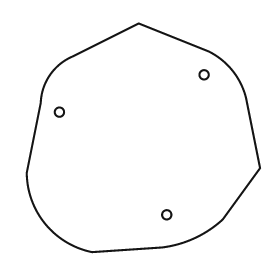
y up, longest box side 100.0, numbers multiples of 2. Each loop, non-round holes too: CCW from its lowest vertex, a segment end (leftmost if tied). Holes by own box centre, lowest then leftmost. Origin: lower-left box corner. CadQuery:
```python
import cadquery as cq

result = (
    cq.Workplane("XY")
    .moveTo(28.0, 0.0)
    .lineTo(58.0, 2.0)
    .threePointArc((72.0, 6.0), (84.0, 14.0))
    .lineTo(100.0, 36.0)
    .lineTo(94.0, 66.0)
    .threePointArc((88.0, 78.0), (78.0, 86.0))
    .lineTo(48.0, 98.0)
    .lineTo(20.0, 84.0)
    .threePointArc((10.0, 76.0), (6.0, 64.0))
    .lineTo(0.0, 34.0)
    .threePointArc((8.0, 12.0), (28.0, 0.0))
    .close()
    .moveTo(60.0, 16.0)
    .circle(2.0)
    .moveTo(14.0, 60.0)
    .circle(2.0)
    .moveTo(76.0, 76.0)
    .circle(2.0)
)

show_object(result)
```